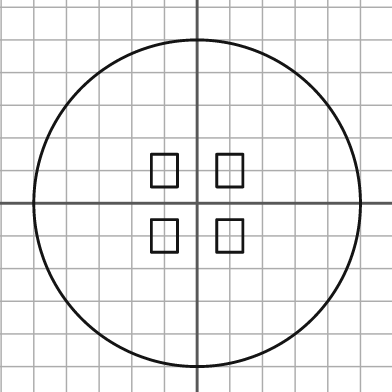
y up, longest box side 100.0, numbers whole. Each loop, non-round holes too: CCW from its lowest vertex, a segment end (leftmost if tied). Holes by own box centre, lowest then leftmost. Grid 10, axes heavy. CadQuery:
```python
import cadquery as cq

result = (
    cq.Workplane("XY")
    .moveTo(0.0, 0.0)
    .circle(50.0)
    .moveTo(-14.0, -15.0)
    .lineTo(-6.0, -15.0)
    .lineTo(-6.0, -5.0)
    .lineTo(-14.0, -5.0)
    .close()
    .moveTo(6.0, -15.0)
    .lineTo(14.0, -15.0)
    .lineTo(14.0, -5.0)
    .lineTo(6.0, -5.0)
    .close()
    .moveTo(-14.0, 5.0)
    .lineTo(-6.0, 5.0)
    .lineTo(-6.0, 15.0)
    .lineTo(-14.0, 15.0)
    .close()
    .moveTo(6.0, 5.0)
    .lineTo(14.0, 5.0)
    .lineTo(14.0, 15.0)
    .lineTo(6.0, 15.0)
    .close()
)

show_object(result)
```